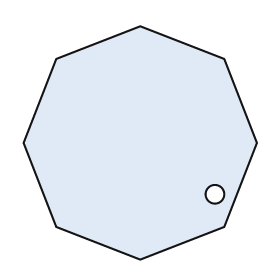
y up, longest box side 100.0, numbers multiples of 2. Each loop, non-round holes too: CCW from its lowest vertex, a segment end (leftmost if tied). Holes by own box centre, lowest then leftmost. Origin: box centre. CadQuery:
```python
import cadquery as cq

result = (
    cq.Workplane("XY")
    .moveTo(0.0, -50.0)
    .lineTo(36.0, -36.0)
    .lineTo(50.0, 0.0)
    .lineTo(36.0, 36.0)
    .lineTo(0.0, 50.0)
    .lineTo(-36.0, 36.0)
    .lineTo(-50.0, 0.0)
    .lineTo(-36.0, -36.0)
    .close()
    .moveTo(32.0, -22.0)
    .circle(4.0)
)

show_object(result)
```